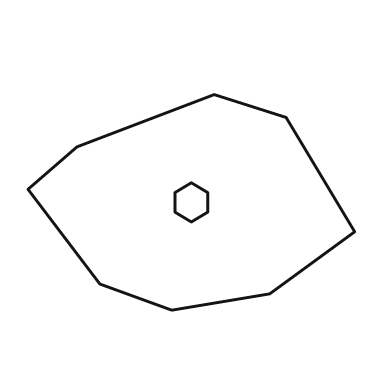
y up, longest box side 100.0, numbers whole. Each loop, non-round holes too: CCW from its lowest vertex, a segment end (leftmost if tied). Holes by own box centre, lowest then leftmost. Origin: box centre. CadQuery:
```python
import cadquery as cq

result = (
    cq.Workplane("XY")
    .moveTo(-6.0, -33.0)
    .lineTo(24.0, -28.0)
    .lineTo(50.0, -9.0)
    .lineTo(29.0, 26.0)
    .lineTo(7.0, 33.0)
    .lineTo(-35.0, 17.0)
    .lineTo(-50.0, 4.0)
    .lineTo(-28.0, -25.0)
    .close()
    .moveTo(0.0, -6.0)
    .lineTo(5.0, -3.0)
    .lineTo(5.0, 3.0)
    .lineTo(0.0, 6.0)
    .lineTo(-5.0, 3.0)
    .lineTo(-5.0, -3.0)
    .close()
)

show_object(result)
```